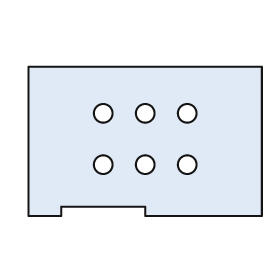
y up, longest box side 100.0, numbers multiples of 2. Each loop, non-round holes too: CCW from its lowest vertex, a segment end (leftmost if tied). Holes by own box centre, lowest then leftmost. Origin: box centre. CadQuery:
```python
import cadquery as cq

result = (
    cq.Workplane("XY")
    .moveTo(-50.0, -32.0)
    .lineTo(-36.0, -32.0)
    .lineTo(-36.0, -28.0)
    .lineTo(0.0, -28.0)
    .lineTo(0.0, -32.0)
    .lineTo(50.0, -32.0)
    .lineTo(50.0, 32.0)
    .lineTo(-50.0, 32.0)
    .close()
    .moveTo(-18.0, -10.0)
    .circle(4.0)
    .moveTo(0.0, -10.0)
    .circle(4.0)
    .moveTo(18.0, -10.0)
    .circle(4.0)
    .moveTo(-18.0, 12.0)
    .circle(4.0)
    .moveTo(0.0, 12.0)
    .circle(4.0)
    .moveTo(18.0, 12.0)
    .circle(4.0)
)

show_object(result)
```